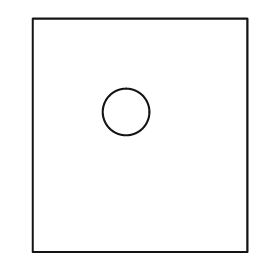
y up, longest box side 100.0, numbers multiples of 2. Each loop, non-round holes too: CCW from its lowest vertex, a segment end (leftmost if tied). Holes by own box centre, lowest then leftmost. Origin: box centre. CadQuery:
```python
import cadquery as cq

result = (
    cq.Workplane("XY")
    .moveTo(-46.0, -50.0)
    .lineTo(46.0, -50.0)
    .lineTo(46.0, 50.0)
    .lineTo(-46.0, 50.0)
    .close()
    .moveTo(-6.0, 10.0)
    .circle(10.0)
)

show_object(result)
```